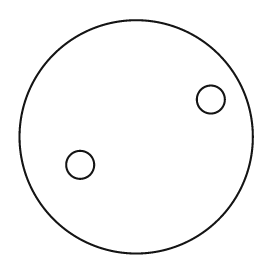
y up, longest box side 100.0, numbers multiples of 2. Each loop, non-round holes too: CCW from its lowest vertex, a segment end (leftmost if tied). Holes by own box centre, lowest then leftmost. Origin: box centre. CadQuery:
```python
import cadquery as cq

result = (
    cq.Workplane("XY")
    .moveTo(0.0, 0.0)
    .circle(50.0)
    .moveTo(-24.0, -12.0)
    .circle(6.0)
    .moveTo(32.0, 16.0)
    .circle(6.0)
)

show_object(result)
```